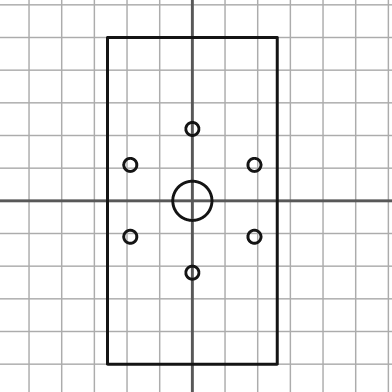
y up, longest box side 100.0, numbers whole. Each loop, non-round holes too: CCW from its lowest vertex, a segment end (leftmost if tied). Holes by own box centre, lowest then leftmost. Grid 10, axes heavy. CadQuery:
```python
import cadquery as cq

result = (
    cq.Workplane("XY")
    .moveTo(-26.0, -50.0)
    .lineTo(26.0, -50.0)
    .lineTo(26.0, 50.0)
    .lineTo(-26.0, 50.0)
    .close()
    .moveTo(0.0, -22.0)
    .circle(2.0)
    .moveTo(-19.0, -11.0)
    .circle(2.0)
    .moveTo(19.0, -11.0)
    .circle(2.0)
    .moveTo(0.0, 0.0)
    .circle(6.0)
    .moveTo(-19.0, 11.0)
    .circle(2.0)
    .moveTo(19.0, 11.0)
    .circle(2.0)
    .moveTo(0.0, 22.0)
    .circle(2.0)
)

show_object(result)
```